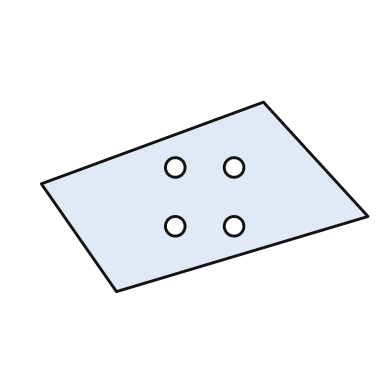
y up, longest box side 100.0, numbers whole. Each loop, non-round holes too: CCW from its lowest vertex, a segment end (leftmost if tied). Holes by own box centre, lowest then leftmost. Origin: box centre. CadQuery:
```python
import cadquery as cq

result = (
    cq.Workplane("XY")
    .moveTo(-27.0, -29.0)
    .lineTo(50.0, -6.0)
    .lineTo(18.0, 29.0)
    .lineTo(-50.0, 4.0)
    .close()
    .moveTo(-9.0, -9.0)
    .circle(3.0)
    .moveTo(9.0, -9.0)
    .circle(3.0)
    .moveTo(-9.0, 9.0)
    .circle(3.0)
    .moveTo(9.0, 9.0)
    .circle(3.0)
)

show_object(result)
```